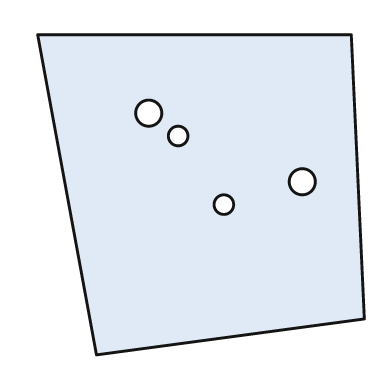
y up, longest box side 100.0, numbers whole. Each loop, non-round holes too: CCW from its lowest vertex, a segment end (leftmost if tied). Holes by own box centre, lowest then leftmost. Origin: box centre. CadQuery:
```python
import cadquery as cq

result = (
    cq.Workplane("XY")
    .moveTo(-32.0, -49.0)
    .lineTo(50.0, -38.0)
    .lineTo(46.0, 49.0)
    .lineTo(-50.0, 49.0)
    .close()
    .moveTo(7.0, -3.0)
    .circle(3.0)
    .moveTo(31.0, 4.0)
    .circle(4.0)
    .moveTo(-7.0, 18.0)
    .circle(3.0)
    .moveTo(-16.0, 25.0)
    .circle(4.0)
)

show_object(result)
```